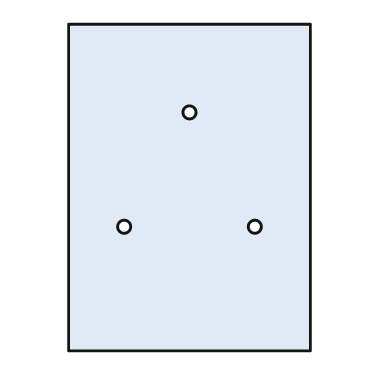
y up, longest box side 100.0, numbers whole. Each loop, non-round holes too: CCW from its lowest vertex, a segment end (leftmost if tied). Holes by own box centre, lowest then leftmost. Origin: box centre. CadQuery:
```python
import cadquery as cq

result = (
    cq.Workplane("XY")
    .moveTo(-37.0, -50.0)
    .lineTo(37.0, -50.0)
    .lineTo(37.0, 50.0)
    .lineTo(-37.0, 50.0)
    .close()
    .moveTo(-20.0, -12.0)
    .circle(2.0)
    .moveTo(20.0, -12.0)
    .circle(2.0)
    .moveTo(0.0, 23.0)
    .circle(2.0)
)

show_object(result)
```